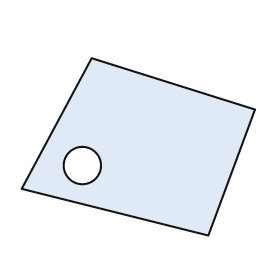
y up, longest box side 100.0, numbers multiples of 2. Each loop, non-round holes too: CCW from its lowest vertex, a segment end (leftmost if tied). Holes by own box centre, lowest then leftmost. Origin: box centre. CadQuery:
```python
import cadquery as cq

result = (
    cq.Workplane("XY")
    .moveTo(30.0, -38.0)
    .lineTo(50.0, 16.0)
    .lineTo(-20.0, 38.0)
    .lineTo(-50.0, -18.0)
    .close()
    .moveTo(-24.0, -8.0)
    .circle(8.0)
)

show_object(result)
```